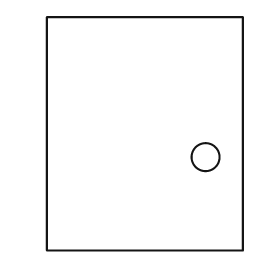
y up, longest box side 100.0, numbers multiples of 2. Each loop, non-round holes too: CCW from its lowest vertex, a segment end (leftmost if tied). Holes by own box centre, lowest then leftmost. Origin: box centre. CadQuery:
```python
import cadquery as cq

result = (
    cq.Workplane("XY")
    .moveTo(-42.0, -50.0)
    .lineTo(42.0, -50.0)
    .lineTo(42.0, 50.0)
    .lineTo(-42.0, 50.0)
    .close()
    .moveTo(26.0, -10.0)
    .circle(6.0)
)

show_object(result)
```